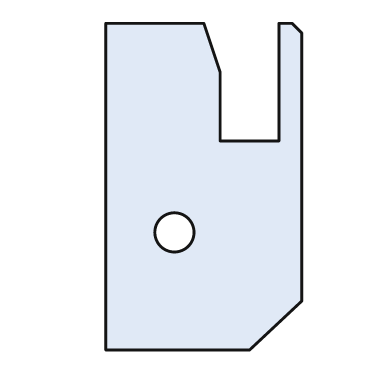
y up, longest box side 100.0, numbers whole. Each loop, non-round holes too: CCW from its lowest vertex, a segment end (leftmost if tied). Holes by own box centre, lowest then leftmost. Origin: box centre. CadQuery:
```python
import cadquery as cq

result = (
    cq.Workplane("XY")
    .moveTo(-30.0, -50.0)
    .lineTo(14.0, -50.0)
    .lineTo(30.0, -35.0)
    .lineTo(30.0, 47.0)
    .lineTo(27.0, 50.0)
    .lineTo(23.0, 50.0)
    .lineTo(23.0, 14.0)
    .lineTo(5.0, 14.0)
    .lineTo(5.0, 35.0)
    .lineTo(0.0, 50.0)
    .lineTo(-30.0, 50.0)
    .close()
    .moveTo(-9.0, -14.0)
    .circle(6.0)
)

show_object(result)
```